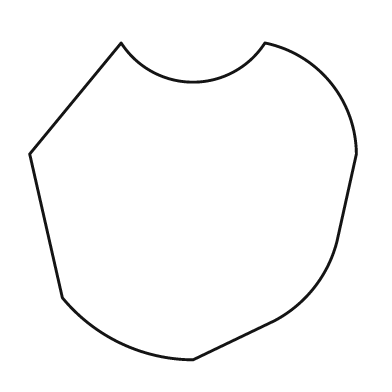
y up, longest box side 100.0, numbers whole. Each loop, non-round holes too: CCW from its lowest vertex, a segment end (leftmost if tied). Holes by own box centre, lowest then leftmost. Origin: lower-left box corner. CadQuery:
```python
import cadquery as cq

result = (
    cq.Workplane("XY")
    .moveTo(50.0, 0.0)
    .lineTo(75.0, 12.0)
    .threePointArc((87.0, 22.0), (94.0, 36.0))
    .lineTo(100.0, 63.0)
    .threePointArc((92.0, 85.0), (72.0, 97.0))
    .threePointArc((50.0, 85.0), (28.0, 97.0))
    .lineTo(0.0, 63.0)
    .lineTo(10.0, 19.0)
    .threePointArc((28.0, 5.0), (50.0, 0.0))
    .close()
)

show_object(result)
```